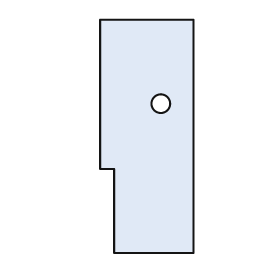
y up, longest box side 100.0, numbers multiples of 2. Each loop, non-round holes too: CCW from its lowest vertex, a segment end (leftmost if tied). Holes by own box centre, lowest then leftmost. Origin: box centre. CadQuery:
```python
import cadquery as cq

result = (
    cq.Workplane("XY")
    .moveTo(-14.0, -50.0)
    .lineTo(20.0, -50.0)
    .lineTo(20.0, 50.0)
    .lineTo(-20.0, 50.0)
    .lineTo(-20.0, -14.0)
    .lineTo(-14.0, -14.0)
    .close()
    .moveTo(6.0, 14.0)
    .circle(4.0)
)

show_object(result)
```